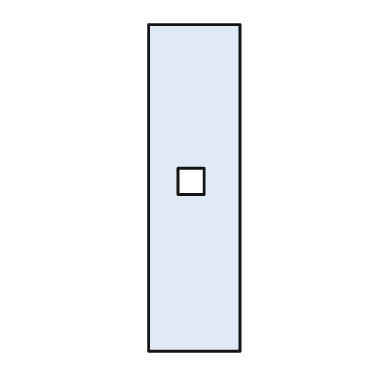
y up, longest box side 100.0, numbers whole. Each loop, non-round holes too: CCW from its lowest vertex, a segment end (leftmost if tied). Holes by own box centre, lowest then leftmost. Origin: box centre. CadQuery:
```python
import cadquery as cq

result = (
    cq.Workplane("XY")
    .moveTo(-14.0, -50.0)
    .lineTo(14.0, -50.0)
    .lineTo(14.0, 50.0)
    .lineTo(-14.0, 50.0)
    .close()
    .moveTo(-5.0, -2.0)
    .lineTo(3.0, -2.0)
    .lineTo(3.0, 6.0)
    .lineTo(-5.0, 6.0)
    .close()
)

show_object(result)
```